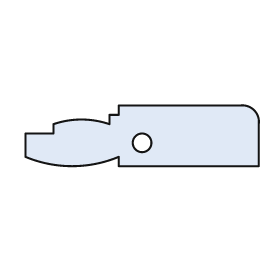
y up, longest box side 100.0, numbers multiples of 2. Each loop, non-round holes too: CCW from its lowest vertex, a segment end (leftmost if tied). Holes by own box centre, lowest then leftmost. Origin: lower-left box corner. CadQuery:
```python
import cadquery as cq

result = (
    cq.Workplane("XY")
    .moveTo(40.0, 0.0)
    .lineTo(100.0, 0.0)
    .lineTo(100.0, 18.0)
    .threePointArc((98.0, 24.0), (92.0, 26.0))
    .lineTo(40.0, 26.0)
    .lineTo(40.0, 22.0)
    .lineTo(36.0, 22.0)
    .lineTo(36.0, 18.0)
    .threePointArc((24.0, 20.0), (12.0, 18.0))
    .lineTo(12.0, 14.0)
    .lineTo(0.0, 14.0)
    .lineTo(0.0, 4.0)
    .threePointArc((20.0, 0.0), (40.0, 4.0))
    .close()
    .moveTo(50.0, 10.0)
    .circle(4.0)
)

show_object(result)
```